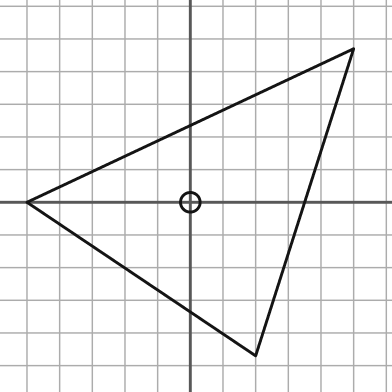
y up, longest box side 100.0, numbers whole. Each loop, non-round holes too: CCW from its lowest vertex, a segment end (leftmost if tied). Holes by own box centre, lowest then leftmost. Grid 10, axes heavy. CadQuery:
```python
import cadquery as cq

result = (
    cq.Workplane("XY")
    .moveTo(20.0, -47.0)
    .lineTo(50.0, 47.0)
    .lineTo(-50.0, 0.0)
    .close()
    .moveTo(0.0, 0.0)
    .circle(3.0)
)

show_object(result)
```